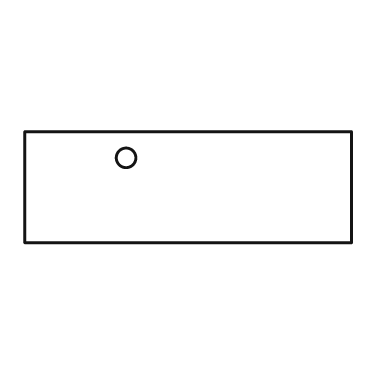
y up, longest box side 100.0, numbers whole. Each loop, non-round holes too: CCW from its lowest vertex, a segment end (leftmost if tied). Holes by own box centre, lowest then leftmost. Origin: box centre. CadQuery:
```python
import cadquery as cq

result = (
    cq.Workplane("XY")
    .moveTo(-50.0, -17.0)
    .lineTo(50.0, -17.0)
    .lineTo(50.0, 17.0)
    .lineTo(-50.0, 17.0)
    .close()
    .moveTo(-19.0, 9.0)
    .circle(3.0)
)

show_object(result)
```